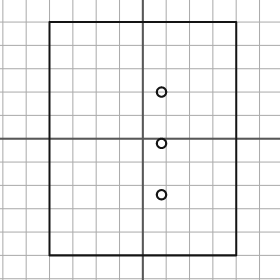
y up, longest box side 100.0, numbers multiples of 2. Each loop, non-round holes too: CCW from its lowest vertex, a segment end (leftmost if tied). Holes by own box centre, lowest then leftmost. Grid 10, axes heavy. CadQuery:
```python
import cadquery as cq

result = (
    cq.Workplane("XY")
    .moveTo(-40.0, -50.0)
    .lineTo(40.0, -50.0)
    .lineTo(40.0, 50.0)
    .lineTo(-40.0, 50.0)
    .close()
    .moveTo(8.0, -24.0)
    .circle(2.0)
    .moveTo(8.0, -2.0)
    .circle(2.0)
    .moveTo(8.0, 20.0)
    .circle(2.0)
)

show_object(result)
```